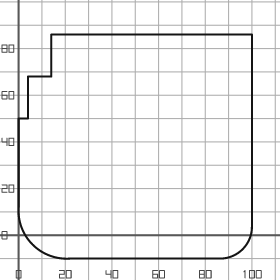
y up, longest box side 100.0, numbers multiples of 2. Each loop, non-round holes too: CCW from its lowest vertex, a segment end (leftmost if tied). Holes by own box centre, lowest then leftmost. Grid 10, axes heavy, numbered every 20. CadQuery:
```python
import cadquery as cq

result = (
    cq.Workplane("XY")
    .moveTo(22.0, -10.0)
    .lineTo(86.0, -10.0)
    .threePointArc((96.0, -6.0), (100.0, 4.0))
    .lineTo(100.0, 86.0)
    .lineTo(14.0, 86.0)
    .lineTo(14.0, 68.0)
    .lineTo(4.0, 68.0)
    .lineTo(4.0, 50.0)
    .lineTo(0.0, 50.0)
    .lineTo(0.0, 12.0)
    .threePointArc((6.0, -4.0), (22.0, -10.0))
    .close()
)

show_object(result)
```